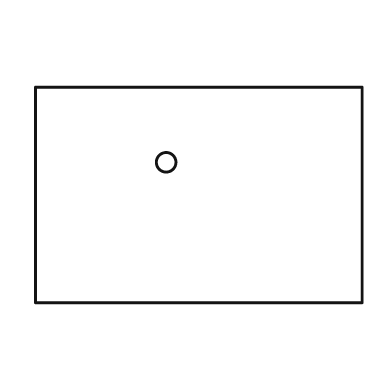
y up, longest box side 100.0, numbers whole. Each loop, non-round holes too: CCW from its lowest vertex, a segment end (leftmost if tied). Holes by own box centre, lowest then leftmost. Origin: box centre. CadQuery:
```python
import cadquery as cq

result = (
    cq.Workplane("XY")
    .moveTo(-50.0, -33.0)
    .lineTo(50.0, -33.0)
    .lineTo(50.0, 33.0)
    .lineTo(-50.0, 33.0)
    .close()
    .moveTo(-10.0, 10.0)
    .circle(3.0)
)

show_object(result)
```